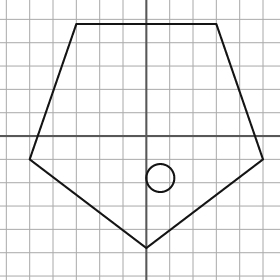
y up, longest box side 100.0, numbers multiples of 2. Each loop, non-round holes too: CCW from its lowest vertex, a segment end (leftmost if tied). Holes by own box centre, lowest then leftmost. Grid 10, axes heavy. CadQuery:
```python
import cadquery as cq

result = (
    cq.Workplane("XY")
    .moveTo(0.0, -48.0)
    .lineTo(50.0, -10.0)
    .lineTo(30.0, 48.0)
    .lineTo(-30.0, 48.0)
    .lineTo(-50.0, -10.0)
    .close()
    .moveTo(6.0, -18.0)
    .circle(6.0)
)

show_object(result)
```